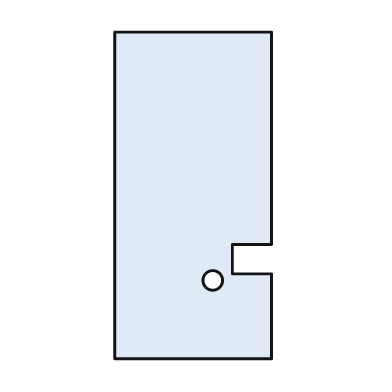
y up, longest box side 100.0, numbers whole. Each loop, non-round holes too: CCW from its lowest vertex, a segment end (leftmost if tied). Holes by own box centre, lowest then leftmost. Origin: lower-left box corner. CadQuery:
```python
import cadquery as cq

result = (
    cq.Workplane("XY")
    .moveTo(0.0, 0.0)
    .lineTo(48.0, 0.0)
    .lineTo(48.0, 26.0)
    .lineTo(36.0, 26.0)
    .lineTo(36.0, 35.0)
    .lineTo(48.0, 35.0)
    .lineTo(48.0, 100.0)
    .lineTo(0.0, 100.0)
    .close()
    .moveTo(30.0, 24.0)
    .circle(3.0)
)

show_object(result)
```